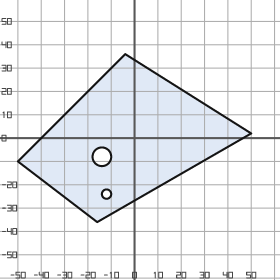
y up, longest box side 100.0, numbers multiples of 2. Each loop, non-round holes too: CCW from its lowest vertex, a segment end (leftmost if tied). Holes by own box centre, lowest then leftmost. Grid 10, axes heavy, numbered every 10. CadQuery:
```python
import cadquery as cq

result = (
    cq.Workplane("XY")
    .moveTo(-16.0, -36.0)
    .lineTo(50.0, 2.0)
    .lineTo(-4.0, 36.0)
    .lineTo(-50.0, -10.0)
    .close()
    .moveTo(-12.0, -24.0)
    .circle(2.0)
    .moveTo(-14.0, -8.0)
    .circle(4.0)
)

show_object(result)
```